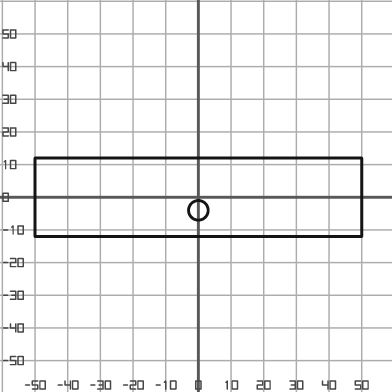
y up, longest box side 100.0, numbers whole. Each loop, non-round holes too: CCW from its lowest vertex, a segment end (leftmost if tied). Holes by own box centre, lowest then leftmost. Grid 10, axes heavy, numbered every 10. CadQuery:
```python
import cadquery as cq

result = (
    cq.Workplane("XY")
    .moveTo(-50.0, -12.0)
    .lineTo(50.0, -12.0)
    .lineTo(50.0, 12.0)
    .lineTo(-50.0, 12.0)
    .close()
    .moveTo(0.0, -4.0)
    .circle(3.0)
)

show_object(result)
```